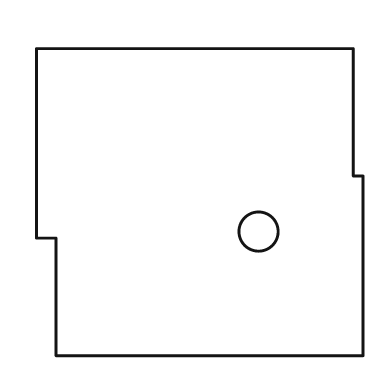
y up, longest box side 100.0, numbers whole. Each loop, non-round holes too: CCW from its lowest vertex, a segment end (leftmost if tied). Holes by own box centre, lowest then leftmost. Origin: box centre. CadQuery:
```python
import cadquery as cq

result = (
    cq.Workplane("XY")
    .moveTo(-44.0, -47.0)
    .lineTo(50.0, -47.0)
    .lineTo(50.0, 8.0)
    .lineTo(47.0, 8.0)
    .lineTo(47.0, 47.0)
    .lineTo(-50.0, 47.0)
    .lineTo(-50.0, -11.0)
    .lineTo(-44.0, -11.0)
    .close()
    .moveTo(18.0, -9.0)
    .circle(6.0)
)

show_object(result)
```